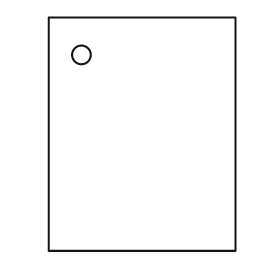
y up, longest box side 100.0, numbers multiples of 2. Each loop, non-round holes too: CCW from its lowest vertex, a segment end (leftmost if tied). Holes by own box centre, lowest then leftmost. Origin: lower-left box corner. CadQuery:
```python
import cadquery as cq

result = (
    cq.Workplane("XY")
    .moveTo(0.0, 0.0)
    .lineTo(80.0, 0.0)
    .lineTo(80.0, 100.0)
    .lineTo(0.0, 100.0)
    .close()
    .moveTo(14.0, 84.0)
    .circle(4.0)
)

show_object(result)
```